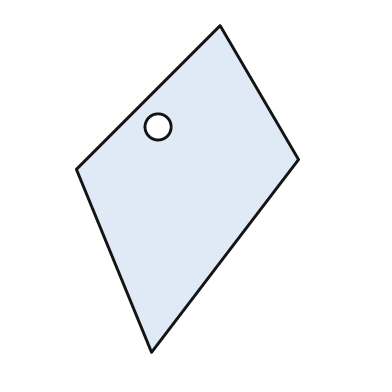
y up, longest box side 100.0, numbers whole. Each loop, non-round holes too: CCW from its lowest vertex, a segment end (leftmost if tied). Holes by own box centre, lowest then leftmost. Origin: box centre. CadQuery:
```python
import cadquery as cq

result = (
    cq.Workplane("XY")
    .moveTo(-11.0, -50.0)
    .lineTo(34.0, 9.0)
    .lineTo(10.0, 50.0)
    .lineTo(-34.0, 6.0)
    .close()
    .moveTo(-9.0, 19.0)
    .circle(4.0)
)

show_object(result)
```